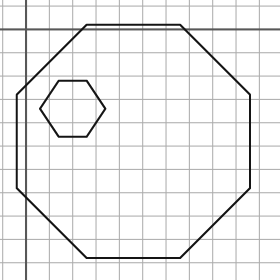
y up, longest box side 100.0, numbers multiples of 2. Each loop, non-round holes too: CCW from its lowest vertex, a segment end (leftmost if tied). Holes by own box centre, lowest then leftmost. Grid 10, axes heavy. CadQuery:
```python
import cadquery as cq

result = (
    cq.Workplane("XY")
    .moveTo(26.0, -98.0)
    .lineTo(66.0, -98.0)
    .lineTo(96.0, -68.0)
    .lineTo(96.0, -28.0)
    .lineTo(66.0, 2.0)
    .lineTo(26.0, 2.0)
    .lineTo(-4.0, -28.0)
    .lineTo(-4.0, -68.0)
    .close()
    .moveTo(14.0, -46.0)
    .lineTo(26.0, -46.0)
    .lineTo(34.0, -34.0)
    .lineTo(26.0, -22.0)
    .lineTo(14.0, -22.0)
    .lineTo(6.0, -34.0)
    .close()
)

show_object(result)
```